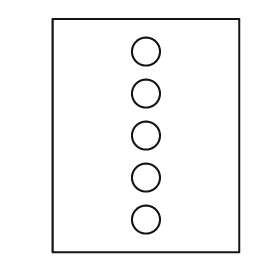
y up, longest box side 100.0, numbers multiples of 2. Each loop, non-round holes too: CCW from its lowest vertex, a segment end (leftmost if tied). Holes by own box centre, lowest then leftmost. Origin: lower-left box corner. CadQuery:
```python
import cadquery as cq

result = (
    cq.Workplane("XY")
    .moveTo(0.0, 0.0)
    .lineTo(80.0, 0.0)
    .lineTo(80.0, 100.0)
    .lineTo(0.0, 100.0)
    .close()
    .moveTo(40.0, 14.0)
    .circle(6.0)
    .moveTo(40.0, 32.0)
    .circle(6.0)
    .moveTo(40.0, 50.0)
    .circle(6.0)
    .moveTo(40.0, 68.0)
    .circle(6.0)
    .moveTo(40.0, 86.0)
    .circle(6.0)
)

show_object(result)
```